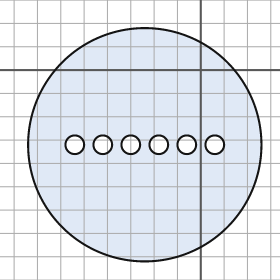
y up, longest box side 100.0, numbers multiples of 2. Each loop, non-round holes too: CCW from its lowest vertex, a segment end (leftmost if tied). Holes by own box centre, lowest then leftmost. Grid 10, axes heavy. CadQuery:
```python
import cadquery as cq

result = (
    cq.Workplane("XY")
    .moveTo(-24.0, -32.0)
    .circle(50.0)
    .moveTo(-54.0, -32.0)
    .circle(4.0)
    .moveTo(-42.0, -32.0)
    .circle(4.0)
    .moveTo(-30.0, -32.0)
    .circle(4.0)
    .moveTo(-18.0, -32.0)
    .circle(4.0)
    .moveTo(-6.0, -32.0)
    .circle(4.0)
    .moveTo(6.0, -32.0)
    .circle(4.0)
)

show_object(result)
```